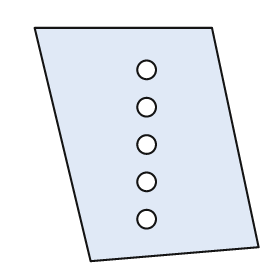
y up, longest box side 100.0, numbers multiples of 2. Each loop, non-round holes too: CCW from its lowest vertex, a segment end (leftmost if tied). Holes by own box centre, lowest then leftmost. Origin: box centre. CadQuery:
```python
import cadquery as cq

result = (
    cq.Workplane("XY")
    .moveTo(-24.0, -50.0)
    .lineTo(48.0, -44.0)
    .lineTo(28.0, 50.0)
    .lineTo(-48.0, 50.0)
    .close()
    .moveTo(0.0, -32.0)
    .circle(4.0)
    .moveTo(0.0, -16.0)
    .circle(4.0)
    .moveTo(0.0, 0.0)
    .circle(4.0)
    .moveTo(0.0, 16.0)
    .circle(4.0)
    .moveTo(0.0, 32.0)
    .circle(4.0)
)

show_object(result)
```